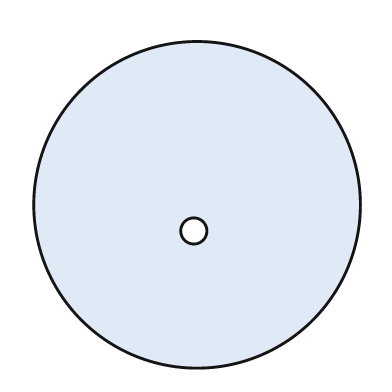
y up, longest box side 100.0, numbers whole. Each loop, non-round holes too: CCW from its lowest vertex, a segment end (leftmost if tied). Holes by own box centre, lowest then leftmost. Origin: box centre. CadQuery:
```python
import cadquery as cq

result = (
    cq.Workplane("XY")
    .moveTo(0.0, 0.0)
    .circle(50.0)
    .moveTo(-1.0, -8.0)
    .circle(4.0)
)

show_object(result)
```